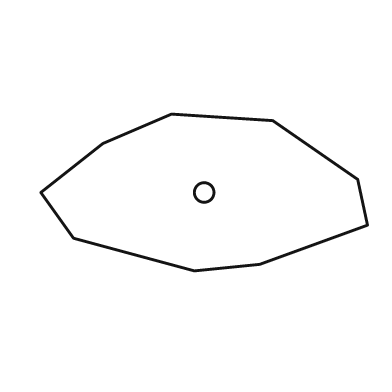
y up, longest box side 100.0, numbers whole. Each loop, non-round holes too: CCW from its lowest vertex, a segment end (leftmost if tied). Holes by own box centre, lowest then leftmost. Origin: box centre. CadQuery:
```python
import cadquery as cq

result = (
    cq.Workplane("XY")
    .moveTo(-3.0, -24.0)
    .lineTo(17.0, -22.0)
    .lineTo(50.0, -10.0)
    .lineTo(47.0, 4.0)
    .lineTo(21.0, 22.0)
    .lineTo(-10.0, 24.0)
    .lineTo(-31.0, 15.0)
    .lineTo(-50.0, 0.0)
    .lineTo(-40.0, -14.0)
    .close()
    .moveTo(0.0, 0.0)
    .circle(3.0)
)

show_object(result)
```